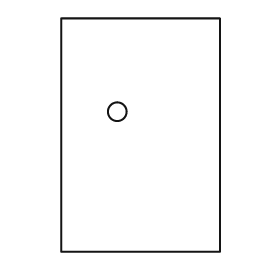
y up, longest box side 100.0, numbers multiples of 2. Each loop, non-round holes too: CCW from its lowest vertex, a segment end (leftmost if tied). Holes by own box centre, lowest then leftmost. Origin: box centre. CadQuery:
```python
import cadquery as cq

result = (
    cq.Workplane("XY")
    .moveTo(-34.0, -50.0)
    .lineTo(34.0, -50.0)
    .lineTo(34.0, 50.0)
    .lineTo(-34.0, 50.0)
    .close()
    .moveTo(-10.0, 10.0)
    .circle(4.0)
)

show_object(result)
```